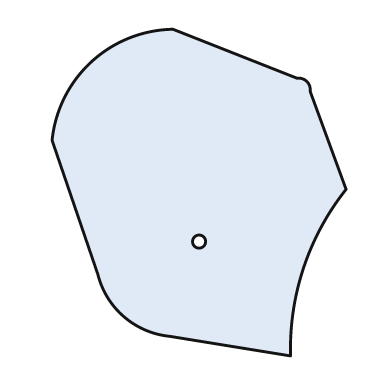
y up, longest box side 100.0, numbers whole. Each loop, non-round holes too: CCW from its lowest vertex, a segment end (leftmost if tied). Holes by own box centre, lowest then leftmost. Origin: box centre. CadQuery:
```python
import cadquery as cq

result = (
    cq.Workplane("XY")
    .moveTo(28.0, -50.0)
    .threePointArc((32.0, -23.0), (45.0, 1.0))
    .lineTo(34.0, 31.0)
    .threePointArc((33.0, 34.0), (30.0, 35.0))
    .lineTo(-8.0, 50.0)
    .threePointArc((-33.0, 40.0), (-45.0, 16.0))
    .lineTo(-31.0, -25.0)
    .threePointArc((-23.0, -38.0), (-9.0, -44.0))
    .close()
    .moveTo(0.0, -15.0)
    .circle(2.0)
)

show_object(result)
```